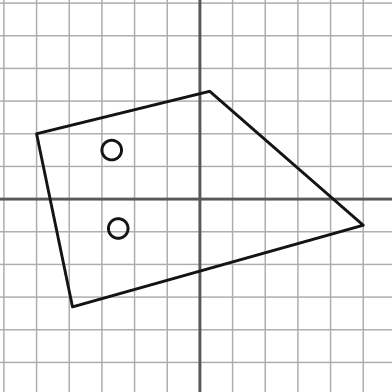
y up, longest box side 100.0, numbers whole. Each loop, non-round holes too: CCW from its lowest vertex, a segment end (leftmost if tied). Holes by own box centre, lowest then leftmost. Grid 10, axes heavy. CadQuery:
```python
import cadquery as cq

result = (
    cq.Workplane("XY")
    .moveTo(-39.0, -33.0)
    .lineTo(50.0, -8.0)
    .lineTo(3.0, 33.0)
    .lineTo(-50.0, 20.0)
    .close()
    .moveTo(-25.0, -9.0)
    .circle(3.0)
    .moveTo(-27.0, 15.0)
    .circle(3.0)
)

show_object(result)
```